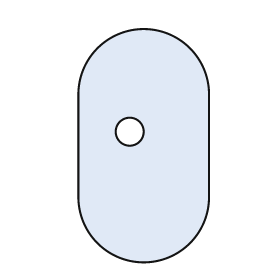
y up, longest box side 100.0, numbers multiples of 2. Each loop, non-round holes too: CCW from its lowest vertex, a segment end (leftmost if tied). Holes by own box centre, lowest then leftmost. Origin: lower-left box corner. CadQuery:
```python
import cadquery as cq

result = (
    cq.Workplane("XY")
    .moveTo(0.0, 28.0)
    .threePointArc((28.0, 0.0), (56.0, 28.0))
    .lineTo(56.0, 72.0)
    .threePointArc((28.0, 100.0), (0.0, 72.0))
    .close()
    .moveTo(22.0, 56.0)
    .circle(6.0)
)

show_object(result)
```